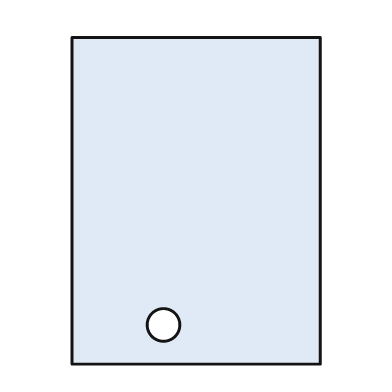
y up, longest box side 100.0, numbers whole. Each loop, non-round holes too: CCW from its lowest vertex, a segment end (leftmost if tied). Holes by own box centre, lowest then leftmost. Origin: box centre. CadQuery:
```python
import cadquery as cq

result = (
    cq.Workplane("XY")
    .moveTo(-38.0, -50.0)
    .lineTo(38.0, -50.0)
    .lineTo(38.0, 50.0)
    .lineTo(-38.0, 50.0)
    .close()
    .moveTo(-10.0, -38.0)
    .circle(5.0)
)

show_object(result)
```